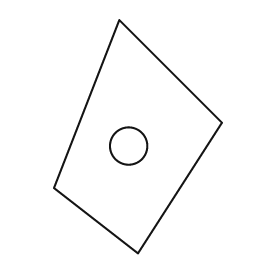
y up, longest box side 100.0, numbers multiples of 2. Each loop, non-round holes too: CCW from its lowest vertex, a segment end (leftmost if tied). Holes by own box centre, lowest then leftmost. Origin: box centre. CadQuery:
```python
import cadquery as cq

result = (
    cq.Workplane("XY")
    .moveTo(0.0, -50.0)
    .lineTo(36.0, 6.0)
    .lineTo(-8.0, 50.0)
    .lineTo(-36.0, -22.0)
    .close()
    .moveTo(-4.0, -4.0)
    .circle(8.0)
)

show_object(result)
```